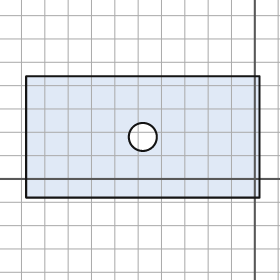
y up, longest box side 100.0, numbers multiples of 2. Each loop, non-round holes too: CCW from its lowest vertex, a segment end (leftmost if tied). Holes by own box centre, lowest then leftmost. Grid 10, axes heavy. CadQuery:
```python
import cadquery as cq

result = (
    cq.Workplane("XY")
    .moveTo(-98.0, -8.0)
    .lineTo(2.0, -8.0)
    .lineTo(2.0, 44.0)
    .lineTo(-98.0, 44.0)
    .close()
    .moveTo(-48.0, 18.0)
    .circle(6.0)
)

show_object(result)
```